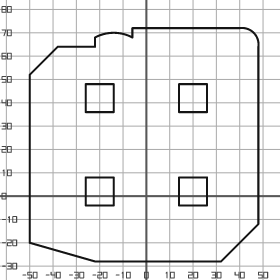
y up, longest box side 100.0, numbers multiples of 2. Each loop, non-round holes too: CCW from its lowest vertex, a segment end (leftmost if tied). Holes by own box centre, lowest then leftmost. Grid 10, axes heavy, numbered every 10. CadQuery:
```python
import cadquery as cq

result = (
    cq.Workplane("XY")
    .moveTo(-22.0, -28.0)
    .lineTo(32.0, -28.0)
    .lineTo(48.0, -12.0)
    .lineTo(48.0, 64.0)
    .threePointArc((46.0, 70.0), (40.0, 72.0))
    .lineTo(-6.0, 72.0)
    .lineTo(-6.0, 68.0)
    .threePointArc((-14.0, 70.0), (-22.0, 68.0))
    .lineTo(-22.0, 64.0)
    .lineTo(-38.0, 64.0)
    .lineTo(-50.0, 52.0)
    .lineTo(-50.0, -20.0)
    .close()
    .moveTo(-26.0, -4.0)
    .lineTo(-14.0, -4.0)
    .lineTo(-14.0, 8.0)
    .lineTo(-26.0, 8.0)
    .close()
    .moveTo(14.0, -4.0)
    .lineTo(26.0, -4.0)
    .lineTo(26.0, 8.0)
    .lineTo(14.0, 8.0)
    .close()
    .moveTo(-26.0, 36.0)
    .lineTo(-14.0, 36.0)
    .lineTo(-14.0, 48.0)
    .lineTo(-26.0, 48.0)
    .close()
    .moveTo(14.0, 36.0)
    .lineTo(26.0, 36.0)
    .lineTo(26.0, 48.0)
    .lineTo(14.0, 48.0)
    .close()
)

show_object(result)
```